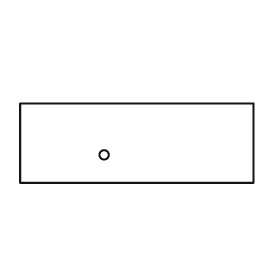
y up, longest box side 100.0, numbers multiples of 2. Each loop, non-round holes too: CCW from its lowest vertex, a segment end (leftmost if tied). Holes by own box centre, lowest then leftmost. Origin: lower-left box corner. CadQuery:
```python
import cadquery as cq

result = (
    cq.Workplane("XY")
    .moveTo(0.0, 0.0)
    .lineTo(100.0, 0.0)
    .lineTo(100.0, 34.0)
    .lineTo(0.0, 34.0)
    .close()
    .moveTo(36.0, 12.0)
    .circle(2.0)
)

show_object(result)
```